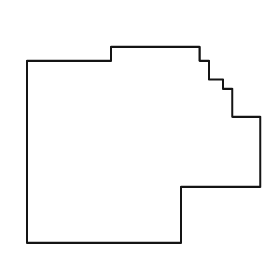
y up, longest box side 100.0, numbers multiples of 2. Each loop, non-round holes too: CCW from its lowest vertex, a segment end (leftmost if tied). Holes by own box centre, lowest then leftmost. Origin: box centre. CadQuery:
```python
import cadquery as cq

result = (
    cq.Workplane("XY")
    .moveTo(-50.0, -42.0)
    .lineTo(16.0, -42.0)
    .lineTo(16.0, -18.0)
    .lineTo(50.0, -18.0)
    .lineTo(50.0, 12.0)
    .lineTo(38.0, 12.0)
    .lineTo(38.0, 24.0)
    .lineTo(34.0, 24.0)
    .lineTo(34.0, 28.0)
    .lineTo(28.0, 28.0)
    .lineTo(28.0, 36.0)
    .lineTo(24.0, 36.0)
    .lineTo(24.0, 42.0)
    .lineTo(-14.0, 42.0)
    .lineTo(-14.0, 36.0)
    .lineTo(-50.0, 36.0)
    .close()
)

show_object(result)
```